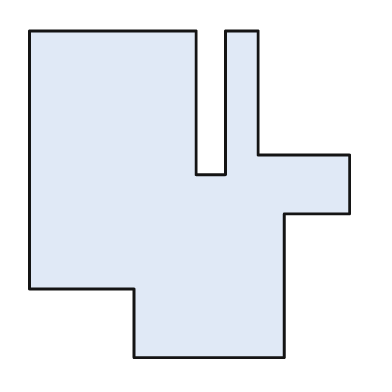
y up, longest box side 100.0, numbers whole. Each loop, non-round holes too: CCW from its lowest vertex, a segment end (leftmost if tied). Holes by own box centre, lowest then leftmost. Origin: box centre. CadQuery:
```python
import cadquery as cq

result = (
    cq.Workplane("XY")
    .moveTo(-17.0, -50.0)
    .lineTo(29.0, -50.0)
    .lineTo(29.0, -6.0)
    .lineTo(49.0, -6.0)
    .lineTo(49.0, 12.0)
    .lineTo(21.0, 12.0)
    .lineTo(21.0, 50.0)
    .lineTo(11.0, 50.0)
    .lineTo(11.0, 6.0)
    .lineTo(2.0, 6.0)
    .lineTo(2.0, 50.0)
    .lineTo(-49.0, 50.0)
    .lineTo(-49.0, -29.0)
    .lineTo(-17.0, -29.0)
    .close()
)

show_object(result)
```